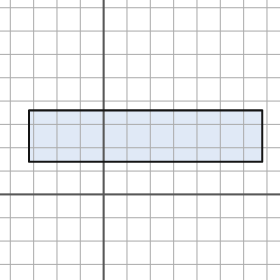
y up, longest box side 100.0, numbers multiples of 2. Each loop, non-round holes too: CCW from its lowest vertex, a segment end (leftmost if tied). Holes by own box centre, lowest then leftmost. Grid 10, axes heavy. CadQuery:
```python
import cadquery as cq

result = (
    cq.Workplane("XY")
    .moveTo(-32.0, 14.0)
    .lineTo(68.0, 14.0)
    .lineTo(68.0, 36.0)
    .lineTo(-32.0, 36.0)
    .close()
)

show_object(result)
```